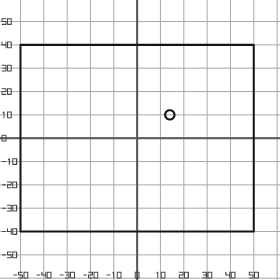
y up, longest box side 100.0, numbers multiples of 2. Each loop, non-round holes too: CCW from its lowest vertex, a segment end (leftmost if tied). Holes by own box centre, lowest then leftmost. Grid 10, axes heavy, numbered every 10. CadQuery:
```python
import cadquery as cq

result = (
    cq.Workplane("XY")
    .moveTo(-50.0, -40.0)
    .lineTo(50.0, -40.0)
    .lineTo(50.0, 40.0)
    .lineTo(-50.0, 40.0)
    .close()
    .moveTo(14.0, 10.0)
    .circle(2.0)
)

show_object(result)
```